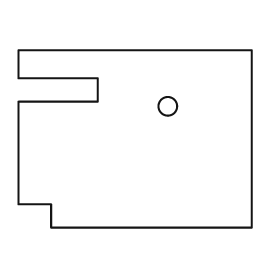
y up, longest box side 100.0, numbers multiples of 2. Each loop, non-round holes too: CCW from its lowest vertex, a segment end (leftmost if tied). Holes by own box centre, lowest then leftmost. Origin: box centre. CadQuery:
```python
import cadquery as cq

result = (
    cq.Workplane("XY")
    .moveTo(-36.0, -38.0)
    .lineTo(50.0, -38.0)
    .lineTo(50.0, 38.0)
    .lineTo(-50.0, 38.0)
    .lineTo(-50.0, 26.0)
    .lineTo(-16.0, 26.0)
    .lineTo(-16.0, 16.0)
    .lineTo(-50.0, 16.0)
    .lineTo(-50.0, -28.0)
    .lineTo(-36.0, -28.0)
    .close()
    .moveTo(14.0, 14.0)
    .circle(4.0)
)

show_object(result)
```